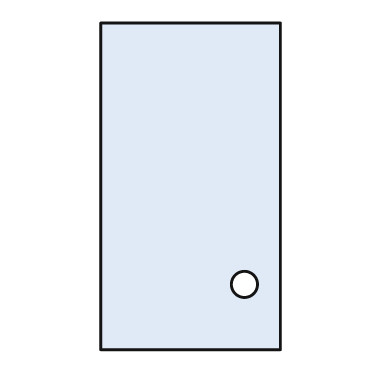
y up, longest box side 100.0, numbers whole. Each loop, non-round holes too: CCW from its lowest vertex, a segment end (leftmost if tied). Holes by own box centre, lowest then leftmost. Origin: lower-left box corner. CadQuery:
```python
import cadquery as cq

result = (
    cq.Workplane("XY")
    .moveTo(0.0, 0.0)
    .lineTo(55.0, 0.0)
    .lineTo(55.0, 100.0)
    .lineTo(0.0, 100.0)
    .close()
    .moveTo(44.0, 20.0)
    .circle(4.0)
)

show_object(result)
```